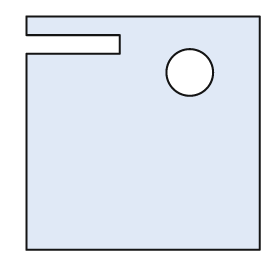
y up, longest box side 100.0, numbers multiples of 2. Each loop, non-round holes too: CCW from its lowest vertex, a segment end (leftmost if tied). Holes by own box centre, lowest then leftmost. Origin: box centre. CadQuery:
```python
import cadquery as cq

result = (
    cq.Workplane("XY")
    .moveTo(-50.0, -50.0)
    .lineTo(50.0, -50.0)
    .lineTo(50.0, 50.0)
    .lineTo(-50.0, 50.0)
    .lineTo(-50.0, 42.0)
    .lineTo(-10.0, 42.0)
    .lineTo(-10.0, 34.0)
    .lineTo(-50.0, 34.0)
    .close()
    .moveTo(20.0, 26.0)
    .circle(10.0)
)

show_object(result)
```